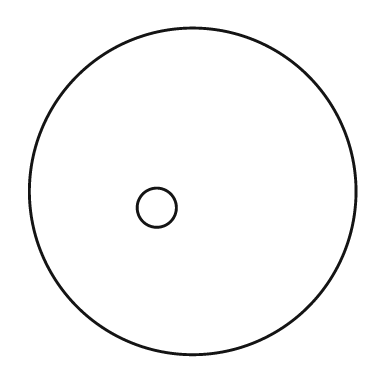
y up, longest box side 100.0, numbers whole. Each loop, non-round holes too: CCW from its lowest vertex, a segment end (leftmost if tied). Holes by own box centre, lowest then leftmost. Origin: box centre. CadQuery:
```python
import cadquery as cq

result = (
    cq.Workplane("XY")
    .moveTo(0.0, 0.0)
    .circle(50.0)
    .moveTo(-11.0, -5.0)
    .circle(6.0)
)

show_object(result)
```